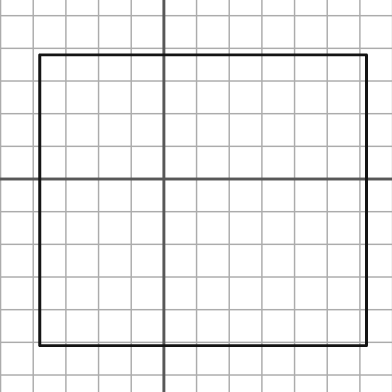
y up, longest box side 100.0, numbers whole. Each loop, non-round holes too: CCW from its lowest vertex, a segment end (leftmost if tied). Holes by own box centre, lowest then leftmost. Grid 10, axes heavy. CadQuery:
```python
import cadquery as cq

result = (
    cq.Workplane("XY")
    .moveTo(-38.0, -51.0)
    .lineTo(62.0, -51.0)
    .lineTo(62.0, 38.0)
    .lineTo(-38.0, 38.0)
    .close()
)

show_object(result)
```